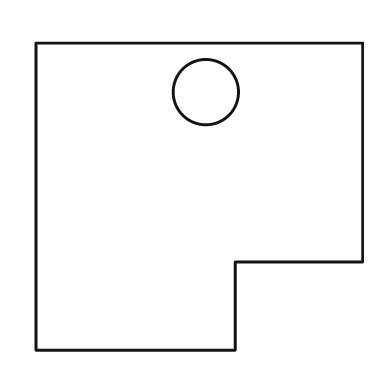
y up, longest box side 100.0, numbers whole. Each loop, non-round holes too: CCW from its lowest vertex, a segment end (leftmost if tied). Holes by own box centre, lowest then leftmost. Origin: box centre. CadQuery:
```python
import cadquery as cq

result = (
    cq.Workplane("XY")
    .moveTo(-50.0, -47.0)
    .lineTo(11.0, -47.0)
    .lineTo(11.0, -20.0)
    .lineTo(50.0, -20.0)
    .lineTo(50.0, 47.0)
    .lineTo(-50.0, 47.0)
    .close()
    .moveTo(2.0, 32.0)
    .circle(10.0)
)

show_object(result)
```